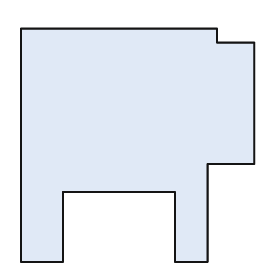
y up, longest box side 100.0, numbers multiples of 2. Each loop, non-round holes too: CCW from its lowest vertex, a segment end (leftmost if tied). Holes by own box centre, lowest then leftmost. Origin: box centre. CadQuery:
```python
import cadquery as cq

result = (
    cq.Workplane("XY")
    .moveTo(-50.0, -50.0)
    .lineTo(-32.0, -50.0)
    .lineTo(-32.0, -20.0)
    .lineTo(16.0, -20.0)
    .lineTo(16.0, -50.0)
    .lineTo(30.0, -50.0)
    .lineTo(30.0, -8.0)
    .lineTo(50.0, -8.0)
    .lineTo(50.0, 44.0)
    .lineTo(34.0, 44.0)
    .lineTo(34.0, 50.0)
    .lineTo(-50.0, 50.0)
    .close()
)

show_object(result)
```